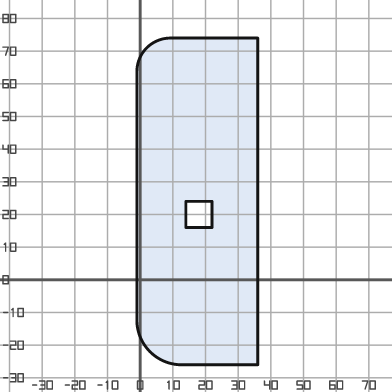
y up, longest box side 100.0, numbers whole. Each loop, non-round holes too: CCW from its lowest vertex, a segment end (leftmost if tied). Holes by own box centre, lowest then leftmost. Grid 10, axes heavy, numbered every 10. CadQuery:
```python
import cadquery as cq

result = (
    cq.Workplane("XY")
    .moveTo(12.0, -26.0)
    .lineTo(36.0, -26.0)
    .lineTo(36.0, 74.0)
    .lineTo(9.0, 74.0)
    .threePointArc((2.0, 71.0), (-1.0, 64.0))
    .lineTo(-1.0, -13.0)
    .threePointArc((3.0, -22.0), (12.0, -26.0))
    .close()
    .moveTo(14.0, 16.0)
    .lineTo(22.0, 16.0)
    .lineTo(22.0, 24.0)
    .lineTo(14.0, 24.0)
    .close()
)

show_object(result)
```